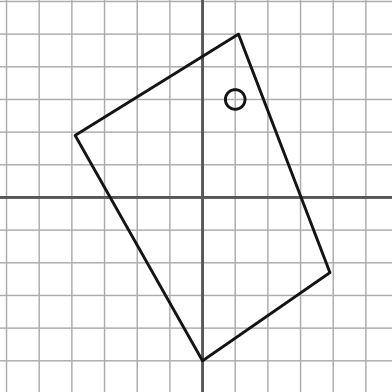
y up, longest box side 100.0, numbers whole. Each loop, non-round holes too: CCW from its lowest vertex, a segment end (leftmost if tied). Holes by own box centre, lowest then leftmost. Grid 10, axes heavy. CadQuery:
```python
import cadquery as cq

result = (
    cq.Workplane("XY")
    .moveTo(0.0, -50.0)
    .lineTo(39.0, -23.0)
    .lineTo(11.0, 50.0)
    .lineTo(-39.0, 19.0)
    .close()
    .moveTo(10.0, 30.0)
    .circle(3.0)
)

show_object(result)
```